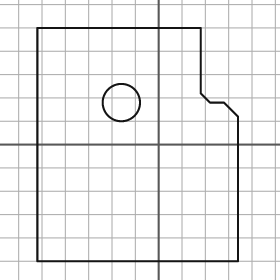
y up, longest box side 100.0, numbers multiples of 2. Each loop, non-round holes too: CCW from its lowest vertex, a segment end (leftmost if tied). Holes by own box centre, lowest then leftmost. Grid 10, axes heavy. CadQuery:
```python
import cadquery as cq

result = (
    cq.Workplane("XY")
    .moveTo(-52.0, -50.0)
    .lineTo(34.0, -50.0)
    .lineTo(34.0, 12.0)
    .lineTo(28.0, 18.0)
    .lineTo(22.0, 18.0)
    .lineTo(18.0, 22.0)
    .lineTo(18.0, 50.0)
    .lineTo(-52.0, 50.0)
    .close()
    .moveTo(-16.0, 18.0)
    .circle(8.0)
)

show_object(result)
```